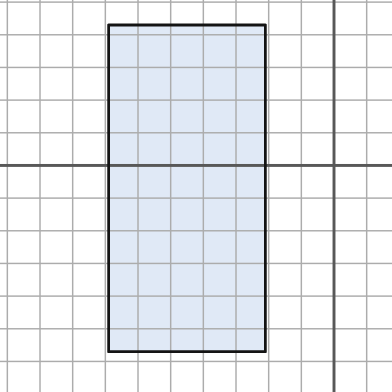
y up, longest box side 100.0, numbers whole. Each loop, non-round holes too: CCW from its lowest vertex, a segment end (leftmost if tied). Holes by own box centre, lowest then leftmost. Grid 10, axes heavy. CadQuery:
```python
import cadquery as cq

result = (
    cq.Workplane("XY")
    .moveTo(-69.0, -57.0)
    .lineTo(-21.0, -57.0)
    .lineTo(-21.0, 43.0)
    .lineTo(-69.0, 43.0)
    .close()
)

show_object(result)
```